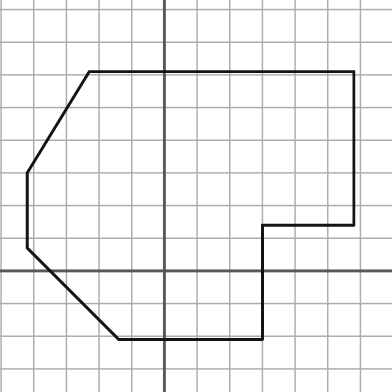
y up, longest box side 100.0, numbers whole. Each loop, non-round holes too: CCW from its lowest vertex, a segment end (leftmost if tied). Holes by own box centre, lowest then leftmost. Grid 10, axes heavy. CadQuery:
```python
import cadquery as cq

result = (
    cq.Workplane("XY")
    .moveTo(-14.0, -21.0)
    .lineTo(30.0, -21.0)
    .lineTo(30.0, 14.0)
    .lineTo(58.0, 14.0)
    .lineTo(58.0, 61.0)
    .lineTo(-23.0, 61.0)
    .lineTo(-42.0, 30.0)
    .lineTo(-42.0, 7.0)
    .close()
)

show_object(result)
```